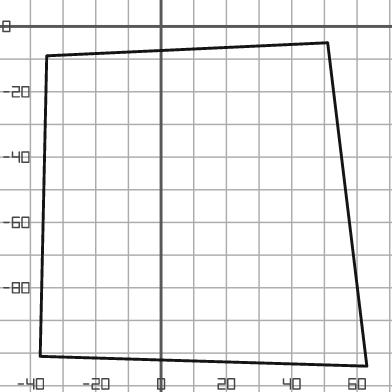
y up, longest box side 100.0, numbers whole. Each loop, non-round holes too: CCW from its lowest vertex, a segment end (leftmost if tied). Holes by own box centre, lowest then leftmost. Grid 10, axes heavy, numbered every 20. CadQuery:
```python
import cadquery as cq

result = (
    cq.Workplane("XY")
    .moveTo(63.0, -104.0)
    .lineTo(51.0, -5.0)
    .lineTo(-35.0, -9.0)
    .lineTo(-37.0, -101.0)
    .close()
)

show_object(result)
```